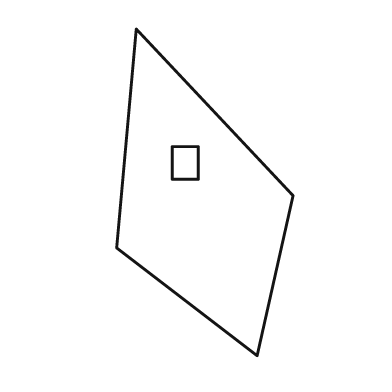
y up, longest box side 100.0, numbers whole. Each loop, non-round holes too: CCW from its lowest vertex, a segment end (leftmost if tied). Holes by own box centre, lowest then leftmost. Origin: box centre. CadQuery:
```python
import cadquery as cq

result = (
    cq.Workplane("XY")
    .moveTo(16.0, -50.0)
    .lineTo(27.0, -1.0)
    .lineTo(-21.0, 50.0)
    .lineTo(-27.0, -17.0)
    .close()
    .moveTo(-10.0, 4.0)
    .lineTo(-2.0, 4.0)
    .lineTo(-2.0, 14.0)
    .lineTo(-10.0, 14.0)
    .close()
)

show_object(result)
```